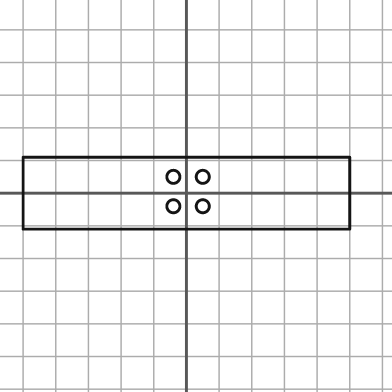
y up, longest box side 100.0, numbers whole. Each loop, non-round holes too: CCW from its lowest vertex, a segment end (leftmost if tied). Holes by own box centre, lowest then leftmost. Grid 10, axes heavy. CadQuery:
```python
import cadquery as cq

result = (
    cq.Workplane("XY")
    .moveTo(-50.0, -11.0)
    .lineTo(50.0, -11.0)
    .lineTo(50.0, 11.0)
    .lineTo(-50.0, 11.0)
    .close()
    .moveTo(-4.0, -4.0)
    .circle(2.0)
    .moveTo(5.0, -4.0)
    .circle(2.0)
    .moveTo(-4.0, 5.0)
    .circle(2.0)
    .moveTo(5.0, 5.0)
    .circle(2.0)
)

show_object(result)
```